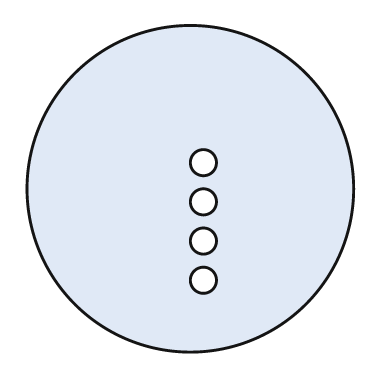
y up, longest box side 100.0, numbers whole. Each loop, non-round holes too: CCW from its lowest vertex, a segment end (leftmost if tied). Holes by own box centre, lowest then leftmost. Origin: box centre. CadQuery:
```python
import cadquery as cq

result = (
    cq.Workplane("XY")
    .moveTo(0.0, 0.0)
    .circle(50.0)
    .moveTo(4.0, -28.0)
    .circle(4.0)
    .moveTo(4.0, -16.0)
    .circle(4.0)
    .moveTo(4.0, -4.0)
    .circle(4.0)
    .moveTo(4.0, 8.0)
    .circle(4.0)
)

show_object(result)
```